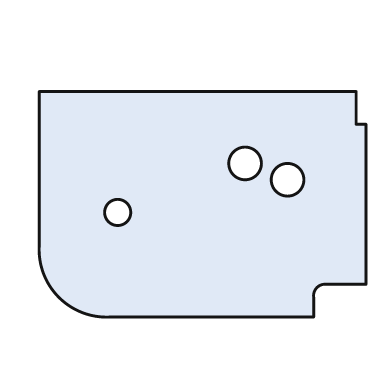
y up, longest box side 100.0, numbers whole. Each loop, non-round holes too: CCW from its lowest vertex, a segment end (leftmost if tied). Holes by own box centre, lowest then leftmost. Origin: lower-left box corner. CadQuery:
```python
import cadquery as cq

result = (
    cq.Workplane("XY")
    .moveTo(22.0, 0.0)
    .lineTo(84.0, 0.0)
    .lineTo(84.0, 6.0)
    .threePointArc((85.0, 9.0), (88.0, 10.0))
    .lineTo(100.0, 10.0)
    .lineTo(100.0, 59.0)
    .lineTo(97.0, 59.0)
    .lineTo(97.0, 69.0)
    .lineTo(0.0, 69.0)
    .lineTo(0.0, 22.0)
    .threePointArc((6.0, 6.0), (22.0, 0.0))
    .close()
    .moveTo(24.0, 32.0)
    .circle(4.0)
    .moveTo(76.0, 42.0)
    .circle(5.0)
    .moveTo(63.0, 47.0)
    .circle(5.0)
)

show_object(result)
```